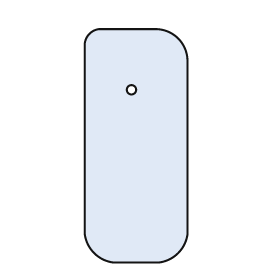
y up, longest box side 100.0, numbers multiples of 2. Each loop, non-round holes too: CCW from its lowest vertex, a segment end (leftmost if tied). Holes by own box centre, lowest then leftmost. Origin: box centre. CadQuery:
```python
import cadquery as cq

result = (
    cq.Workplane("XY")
    .moveTo(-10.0, -50.0)
    .lineTo(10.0, -50.0)
    .threePointArc((18.0, -46.0), (22.0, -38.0))
    .lineTo(22.0, 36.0)
    .threePointArc((18.0, 46.0), (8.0, 50.0))
    .lineTo(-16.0, 50.0)
    .threePointArc((-20.0, 48.0), (-22.0, 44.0))
    .lineTo(-22.0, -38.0)
    .threePointArc((-18.0, -46.0), (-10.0, -50.0))
    .close()
    .moveTo(-2.0, 24.0)
    .circle(2.0)
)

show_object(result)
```